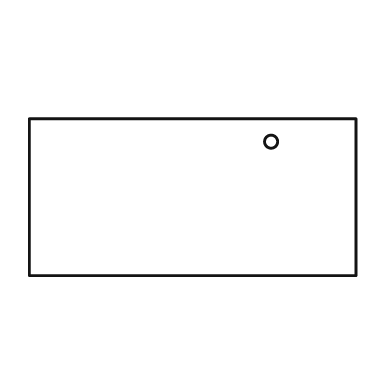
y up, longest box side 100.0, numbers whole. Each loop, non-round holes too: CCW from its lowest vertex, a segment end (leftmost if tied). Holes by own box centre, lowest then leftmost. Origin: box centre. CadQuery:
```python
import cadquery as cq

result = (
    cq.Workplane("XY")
    .moveTo(-50.0, -24.0)
    .lineTo(50.0, -24.0)
    .lineTo(50.0, 24.0)
    .lineTo(-50.0, 24.0)
    .close()
    .moveTo(24.0, 17.0)
    .circle(2.0)
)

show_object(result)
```